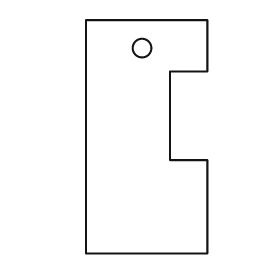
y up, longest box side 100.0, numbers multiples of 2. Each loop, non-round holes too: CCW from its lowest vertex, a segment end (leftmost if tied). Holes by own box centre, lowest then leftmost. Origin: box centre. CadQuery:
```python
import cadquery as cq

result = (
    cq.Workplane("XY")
    .moveTo(-26.0, -50.0)
    .lineTo(26.0, -50.0)
    .lineTo(26.0, -10.0)
    .lineTo(10.0, -10.0)
    .lineTo(10.0, 28.0)
    .lineTo(26.0, 28.0)
    .lineTo(26.0, 50.0)
    .lineTo(-26.0, 50.0)
    .close()
    .moveTo(-2.0, 38.0)
    .circle(4.0)
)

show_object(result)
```